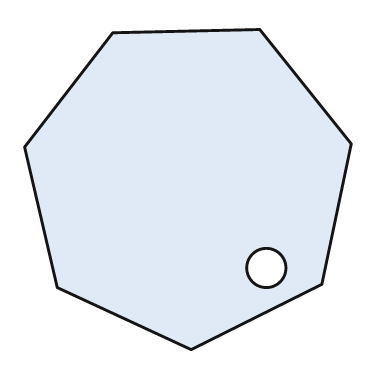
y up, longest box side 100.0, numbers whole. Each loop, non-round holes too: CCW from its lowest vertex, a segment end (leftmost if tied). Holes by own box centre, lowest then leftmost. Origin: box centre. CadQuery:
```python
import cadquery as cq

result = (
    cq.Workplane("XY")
    .moveTo(1.0, -49.0)
    .lineTo(41.0, -29.0)
    .lineTo(50.0, 14.0)
    .lineTo(22.0, 49.0)
    .lineTo(-23.0, 48.0)
    .lineTo(-50.0, 13.0)
    .lineTo(-40.0, -30.0)
    .close()
    .moveTo(24.0, -24.0)
    .circle(6.0)
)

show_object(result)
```